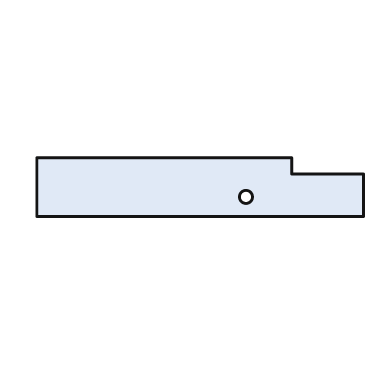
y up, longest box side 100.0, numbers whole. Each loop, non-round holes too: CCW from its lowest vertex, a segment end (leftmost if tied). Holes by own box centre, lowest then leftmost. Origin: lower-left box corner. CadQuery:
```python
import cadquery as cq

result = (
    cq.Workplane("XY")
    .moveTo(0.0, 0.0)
    .lineTo(100.0, 0.0)
    .lineTo(100.0, 13.0)
    .lineTo(78.0, 13.0)
    .lineTo(78.0, 18.0)
    .lineTo(0.0, 18.0)
    .close()
    .moveTo(64.0, 6.0)
    .circle(2.0)
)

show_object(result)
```